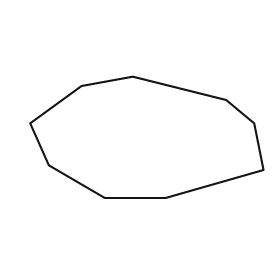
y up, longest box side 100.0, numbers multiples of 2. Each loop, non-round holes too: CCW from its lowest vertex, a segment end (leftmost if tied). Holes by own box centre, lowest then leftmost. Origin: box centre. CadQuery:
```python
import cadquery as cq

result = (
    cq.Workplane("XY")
    .moveTo(-18.0, -26.0)
    .lineTo(8.0, -26.0)
    .lineTo(50.0, -14.0)
    .lineTo(46.0, 6.0)
    .lineTo(34.0, 16.0)
    .lineTo(-6.0, 26.0)
    .lineTo(-28.0, 22.0)
    .lineTo(-50.0, 6.0)
    .lineTo(-42.0, -12.0)
    .close()
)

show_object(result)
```